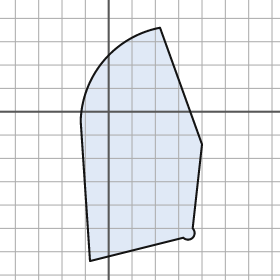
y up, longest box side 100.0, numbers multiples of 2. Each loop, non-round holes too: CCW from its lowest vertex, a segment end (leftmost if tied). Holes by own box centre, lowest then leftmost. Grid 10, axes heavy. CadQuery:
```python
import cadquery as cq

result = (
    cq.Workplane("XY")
    .moveTo(-8.0, -64.0)
    .lineTo(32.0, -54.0)
    .threePointArc((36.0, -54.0), (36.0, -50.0))
    .lineTo(40.0, -14.0)
    .lineTo(22.0, 36.0)
    .threePointArc((-2.0, 22.0), (-12.0, -4.0))
    .close()
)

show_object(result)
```